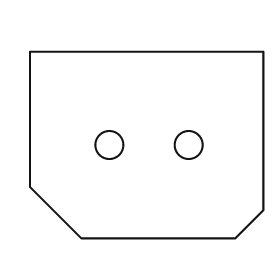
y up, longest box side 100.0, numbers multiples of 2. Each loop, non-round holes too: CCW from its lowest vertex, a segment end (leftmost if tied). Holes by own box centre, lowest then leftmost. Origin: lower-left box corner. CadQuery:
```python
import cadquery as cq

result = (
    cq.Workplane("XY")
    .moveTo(22.0, 0.0)
    .lineTo(88.0, 0.0)
    .lineTo(100.0, 12.0)
    .lineTo(100.0, 80.0)
    .lineTo(0.0, 80.0)
    .lineTo(0.0, 22.0)
    .close()
    .moveTo(34.0, 40.0)
    .circle(6.0)
    .moveTo(68.0, 40.0)
    .circle(6.0)
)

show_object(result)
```